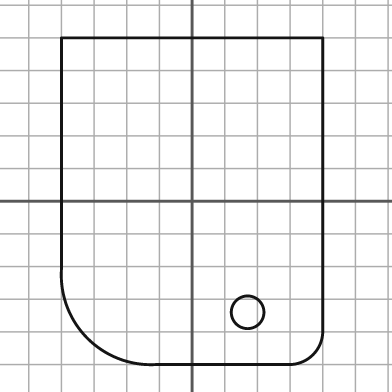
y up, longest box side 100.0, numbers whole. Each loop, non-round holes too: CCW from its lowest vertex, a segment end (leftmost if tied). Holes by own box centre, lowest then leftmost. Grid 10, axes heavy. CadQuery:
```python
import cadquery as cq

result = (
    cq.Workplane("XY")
    .moveTo(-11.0, -50.0)
    .lineTo(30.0, -50.0)
    .threePointArc((37.0, -47.0), (40.0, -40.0))
    .lineTo(40.0, 50.0)
    .lineTo(-40.0, 50.0)
    .lineTo(-40.0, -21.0)
    .threePointArc((-32.0, -42.0), (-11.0, -50.0))
    .close()
    .moveTo(17.0, -34.0)
    .circle(5.0)
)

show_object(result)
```